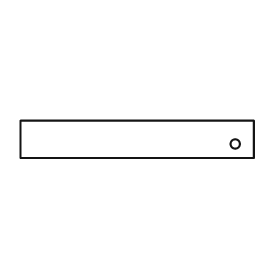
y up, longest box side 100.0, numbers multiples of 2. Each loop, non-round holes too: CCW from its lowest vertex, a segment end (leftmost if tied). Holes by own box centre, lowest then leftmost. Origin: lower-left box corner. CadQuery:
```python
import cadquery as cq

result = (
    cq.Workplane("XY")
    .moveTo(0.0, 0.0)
    .lineTo(100.0, 0.0)
    .lineTo(100.0, 16.0)
    .lineTo(0.0, 16.0)
    .close()
    .moveTo(92.0, 6.0)
    .circle(2.0)
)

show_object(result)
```